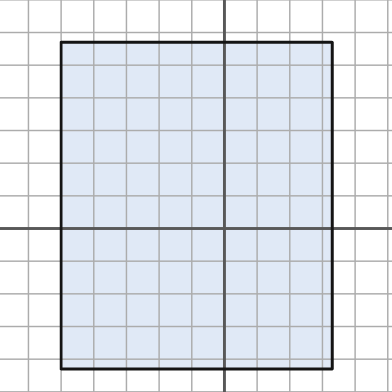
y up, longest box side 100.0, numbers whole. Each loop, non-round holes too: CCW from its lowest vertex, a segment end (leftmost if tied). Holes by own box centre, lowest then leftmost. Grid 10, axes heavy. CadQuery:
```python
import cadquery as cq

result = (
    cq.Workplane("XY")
    .moveTo(-50.0, -43.0)
    .lineTo(33.0, -43.0)
    .lineTo(33.0, 57.0)
    .lineTo(-50.0, 57.0)
    .close()
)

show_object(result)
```